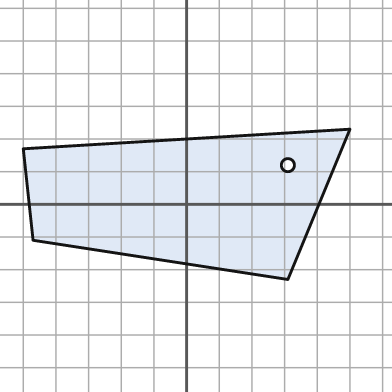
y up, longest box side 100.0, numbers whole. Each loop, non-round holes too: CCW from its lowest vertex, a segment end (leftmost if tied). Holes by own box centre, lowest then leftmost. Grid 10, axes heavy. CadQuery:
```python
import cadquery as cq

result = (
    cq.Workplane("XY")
    .moveTo(31.0, -23.0)
    .lineTo(50.0, 23.0)
    .lineTo(-50.0, 17.0)
    .lineTo(-47.0, -11.0)
    .close()
    .moveTo(31.0, 12.0)
    .circle(2.0)
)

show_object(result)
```